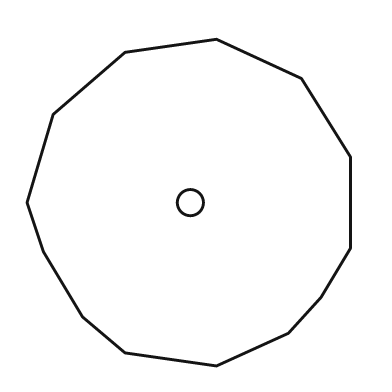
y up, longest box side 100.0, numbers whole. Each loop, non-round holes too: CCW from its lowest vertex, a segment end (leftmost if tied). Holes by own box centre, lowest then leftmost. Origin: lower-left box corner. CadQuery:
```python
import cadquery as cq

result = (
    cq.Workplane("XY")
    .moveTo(58.0, 0.0)
    .lineTo(80.0, 10.0)
    .lineTo(90.0, 21.0)
    .lineTo(99.0, 36.0)
    .lineTo(99.0, 64.0)
    .lineTo(84.0, 88.0)
    .lineTo(58.0, 100.0)
    .lineTo(30.0, 96.0)
    .lineTo(8.0, 77.0)
    .lineTo(0.0, 50.0)
    .lineTo(5.0, 35.0)
    .lineTo(17.0, 15.0)
    .lineTo(30.0, 4.0)
    .close()
    .moveTo(50.0, 50.0)
    .circle(4.0)
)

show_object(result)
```